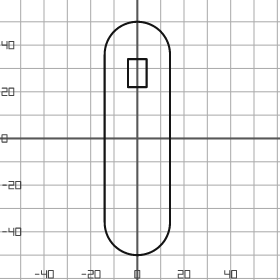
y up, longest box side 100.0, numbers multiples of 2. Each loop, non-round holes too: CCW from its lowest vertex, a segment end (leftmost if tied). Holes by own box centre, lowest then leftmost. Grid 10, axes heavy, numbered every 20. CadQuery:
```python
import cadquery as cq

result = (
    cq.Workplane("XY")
    .moveTo(-14.0, -36.0)
    .threePointArc((0.0, -50.0), (14.0, -36.0))
    .lineTo(14.0, 36.0)
    .threePointArc((0.0, 50.0), (-14.0, 36.0))
    .close()
    .moveTo(-4.0, 22.0)
    .lineTo(4.0, 22.0)
    .lineTo(4.0, 34.0)
    .lineTo(-4.0, 34.0)
    .close()
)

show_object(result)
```